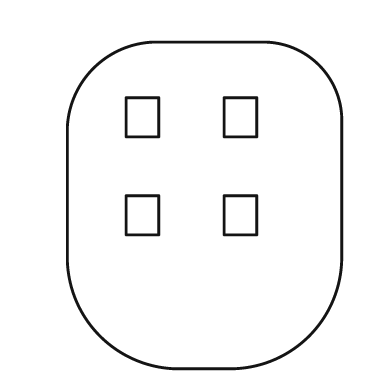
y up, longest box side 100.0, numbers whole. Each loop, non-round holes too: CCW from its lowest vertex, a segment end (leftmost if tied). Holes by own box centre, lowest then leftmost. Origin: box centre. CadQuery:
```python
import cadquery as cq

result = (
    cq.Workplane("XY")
    .moveTo(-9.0, -50.0)
    .lineTo(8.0, -50.0)
    .threePointArc((32.0, -40.0), (42.0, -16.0))
    .lineTo(42.0, 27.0)
    .threePointArc((35.0, 43.0), (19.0, 50.0))
    .lineTo(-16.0, 50.0)
    .threePointArc((-34.0, 42.0), (-42.0, 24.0))
    .lineTo(-42.0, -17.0)
    .threePointArc((-32.0, -40.0), (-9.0, -50.0))
    .close()
    .moveTo(-24.0, -9.0)
    .lineTo(-14.0, -9.0)
    .lineTo(-14.0, 3.0)
    .lineTo(-24.0, 3.0)
    .close()
    .moveTo(6.0, -9.0)
    .lineTo(16.0, -9.0)
    .lineTo(16.0, 3.0)
    .lineTo(6.0, 3.0)
    .close()
    .moveTo(-24.0, 21.0)
    .lineTo(-14.0, 21.0)
    .lineTo(-14.0, 33.0)
    .lineTo(-24.0, 33.0)
    .close()
    .moveTo(6.0, 21.0)
    .lineTo(16.0, 21.0)
    .lineTo(16.0, 33.0)
    .lineTo(6.0, 33.0)
    .close()
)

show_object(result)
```